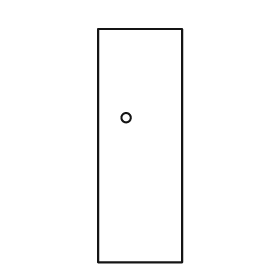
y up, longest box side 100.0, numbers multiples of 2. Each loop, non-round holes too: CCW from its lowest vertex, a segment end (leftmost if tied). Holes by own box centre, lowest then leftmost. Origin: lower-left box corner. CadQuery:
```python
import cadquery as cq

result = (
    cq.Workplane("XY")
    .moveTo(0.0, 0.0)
    .lineTo(36.0, 0.0)
    .lineTo(36.0, 100.0)
    .lineTo(0.0, 100.0)
    .close()
    .moveTo(12.0, 62.0)
    .circle(2.0)
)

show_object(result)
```